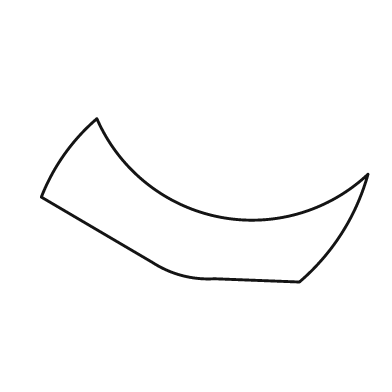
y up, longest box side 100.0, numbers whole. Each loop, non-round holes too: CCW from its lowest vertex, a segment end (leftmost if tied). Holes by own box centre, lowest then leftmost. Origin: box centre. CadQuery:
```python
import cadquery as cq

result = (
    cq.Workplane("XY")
    .moveTo(29.0, -25.0)
    .threePointArc((42.0, -10.0), (50.0, 8.0))
    .threePointArc((4.0, -5.0), (-33.0, 25.0))
    .threePointArc((-43.0, 14.0), (-50.0, 1.0))
    .lineTo(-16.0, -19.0)
    .threePointArc((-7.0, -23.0), (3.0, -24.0))
    .close()
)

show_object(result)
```